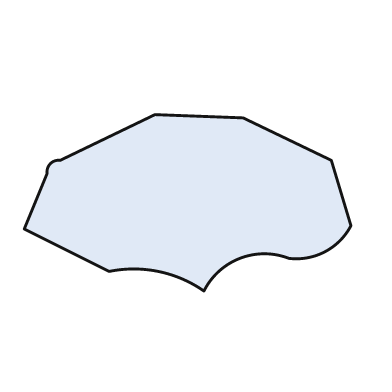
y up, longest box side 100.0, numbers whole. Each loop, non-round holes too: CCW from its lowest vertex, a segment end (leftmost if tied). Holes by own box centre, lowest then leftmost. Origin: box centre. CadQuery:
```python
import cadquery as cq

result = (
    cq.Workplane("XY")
    .moveTo(5.0, -27.0)
    .threePointArc((16.0, -17.0), (31.0, -17.0))
    .threePointArc((42.0, -15.0), (50.0, -7.0))
    .lineTo(44.0, 13.0)
    .lineTo(17.0, 26.0)
    .lineTo(-10.0, 27.0)
    .lineTo(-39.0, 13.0)
    .threePointArc((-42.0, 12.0), (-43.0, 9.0))
    .lineTo(-50.0, -8.0)
    .lineTo(-24.0, -21.0)
    .threePointArc((-9.0, -21.0), (5.0, -27.0))
    .close()
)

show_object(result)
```